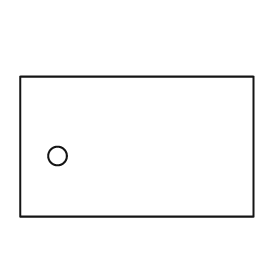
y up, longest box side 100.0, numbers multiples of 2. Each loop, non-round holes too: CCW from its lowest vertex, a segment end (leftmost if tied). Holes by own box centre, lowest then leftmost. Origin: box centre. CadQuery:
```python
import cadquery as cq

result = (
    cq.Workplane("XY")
    .moveTo(-50.0, -30.0)
    .lineTo(50.0, -30.0)
    .lineTo(50.0, 30.0)
    .lineTo(-50.0, 30.0)
    .close()
    .moveTo(-34.0, -4.0)
    .circle(4.0)
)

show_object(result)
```